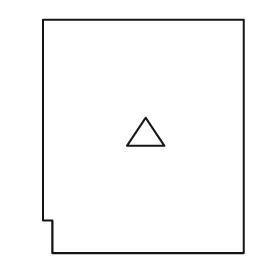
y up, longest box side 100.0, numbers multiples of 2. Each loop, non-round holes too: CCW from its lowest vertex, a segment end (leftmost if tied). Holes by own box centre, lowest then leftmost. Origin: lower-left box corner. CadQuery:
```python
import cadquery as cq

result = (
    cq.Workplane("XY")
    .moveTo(4.0, 0.0)
    .lineTo(86.0, 0.0)
    .lineTo(86.0, 100.0)
    .lineTo(0.0, 100.0)
    .lineTo(0.0, 14.0)
    .lineTo(4.0, 14.0)
    .close()
    .moveTo(36.0, 46.0)
    .lineTo(52.0, 46.0)
    .lineTo(44.0, 58.0)
    .close()
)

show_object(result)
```